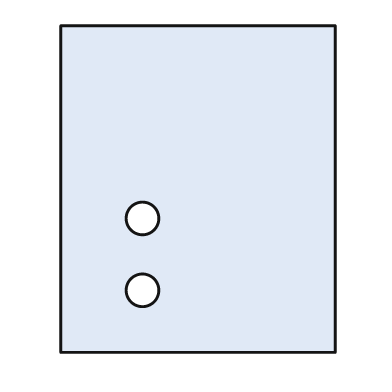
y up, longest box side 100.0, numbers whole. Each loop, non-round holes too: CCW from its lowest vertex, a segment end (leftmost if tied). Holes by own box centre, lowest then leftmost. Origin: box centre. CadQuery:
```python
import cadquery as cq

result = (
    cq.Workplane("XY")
    .moveTo(-42.0, -50.0)
    .lineTo(42.0, -50.0)
    .lineTo(42.0, 50.0)
    .lineTo(-42.0, 50.0)
    .close()
    .moveTo(-17.0, -31.0)
    .circle(5.0)
    .moveTo(-17.0, -9.0)
    .circle(5.0)
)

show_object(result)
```